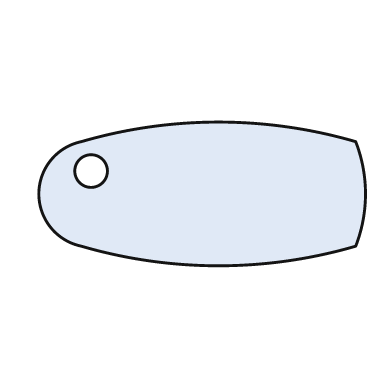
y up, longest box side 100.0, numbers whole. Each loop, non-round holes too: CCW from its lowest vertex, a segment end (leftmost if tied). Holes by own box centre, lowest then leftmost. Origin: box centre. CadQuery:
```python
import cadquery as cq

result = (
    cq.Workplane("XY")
    .moveTo(-37.0, -16.0)
    .threePointArc((5.0, -22.0), (47.0, -16.0))
    .threePointArc((50.0, 0.0), (47.0, 16.0))
    .threePointArc((5.0, 22.0), (-37.0, 16.0))
    .threePointArc((-50.0, 0.0), (-37.0, -16.0))
    .close()
    .moveTo(-34.0, 7.0)
    .circle(5.0)
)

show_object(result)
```